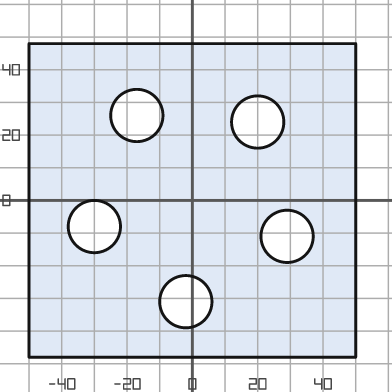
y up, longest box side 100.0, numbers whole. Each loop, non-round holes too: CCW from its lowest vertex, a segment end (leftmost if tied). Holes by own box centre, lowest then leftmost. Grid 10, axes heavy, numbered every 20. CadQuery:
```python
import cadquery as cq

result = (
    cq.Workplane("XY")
    .moveTo(-50.0, -48.0)
    .lineTo(50.0, -48.0)
    .lineTo(50.0, 48.0)
    .lineTo(-50.0, 48.0)
    .close()
    .moveTo(-2.0, -31.0)
    .circle(8.0)
    .moveTo(29.0, -11.0)
    .circle(8.0)
    .moveTo(-30.0, -8.0)
    .circle(8.0)
    .moveTo(20.0, 24.0)
    .circle(8.0)
    .moveTo(-17.0, 26.0)
    .circle(8.0)
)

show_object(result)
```